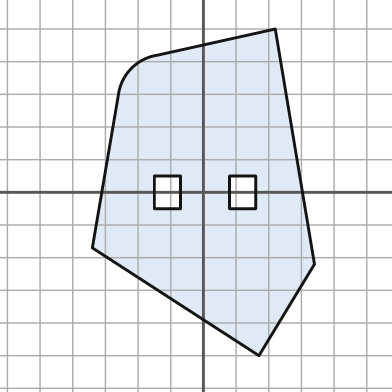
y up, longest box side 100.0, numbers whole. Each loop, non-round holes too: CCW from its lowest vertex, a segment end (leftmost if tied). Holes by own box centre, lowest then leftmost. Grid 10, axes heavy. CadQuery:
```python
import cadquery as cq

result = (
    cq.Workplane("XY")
    .moveTo(17.0, -50.0)
    .lineTo(34.0, -22.0)
    .lineTo(22.0, 50.0)
    .lineTo(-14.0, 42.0)
    .threePointArc((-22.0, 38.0), (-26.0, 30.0))
    .lineTo(-34.0, -17.0)
    .close()
    .moveTo(-15.0, -5.0)
    .lineTo(-7.0, -5.0)
    .lineTo(-7.0, 5.0)
    .lineTo(-15.0, 5.0)
    .close()
    .moveTo(8.0, -5.0)
    .lineTo(16.0, -5.0)
    .lineTo(16.0, 5.0)
    .lineTo(8.0, 5.0)
    .close()
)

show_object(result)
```